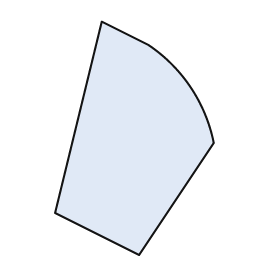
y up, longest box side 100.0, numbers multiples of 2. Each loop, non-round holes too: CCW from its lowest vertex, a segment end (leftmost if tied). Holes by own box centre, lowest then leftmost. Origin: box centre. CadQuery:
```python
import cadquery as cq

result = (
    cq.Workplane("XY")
    .moveTo(2.0, -50.0)
    .lineTo(34.0, -2.0)
    .threePointArc((24.0, 22.0), (6.0, 40.0))
    .lineTo(-14.0, 50.0)
    .lineTo(-34.0, -32.0)
    .close()
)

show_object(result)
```